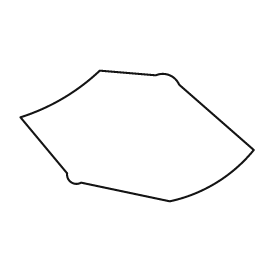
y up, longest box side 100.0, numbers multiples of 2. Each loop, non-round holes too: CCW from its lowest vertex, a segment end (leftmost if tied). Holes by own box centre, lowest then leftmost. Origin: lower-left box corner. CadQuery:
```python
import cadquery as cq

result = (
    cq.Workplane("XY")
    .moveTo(64.0, 0.0)
    .threePointArc((84.0, 8.0), (100.0, 22.0))
    .lineTo(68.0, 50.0)
    .threePointArc((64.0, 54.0), (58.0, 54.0))
    .lineTo(34.0, 56.0)
    .threePointArc((18.0, 44.0), (0.0, 36.0))
    .lineTo(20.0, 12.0)
    .threePointArc((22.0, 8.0), (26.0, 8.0))
    .close()
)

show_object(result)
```